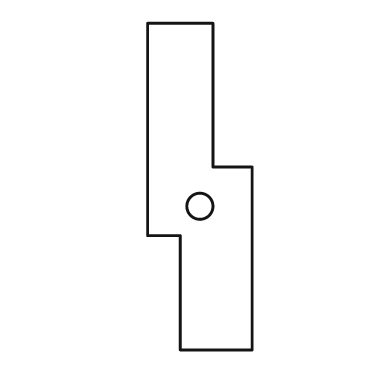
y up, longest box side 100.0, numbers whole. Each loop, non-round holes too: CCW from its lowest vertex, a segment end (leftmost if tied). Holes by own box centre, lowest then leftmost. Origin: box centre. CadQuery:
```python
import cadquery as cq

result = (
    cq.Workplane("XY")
    .moveTo(-6.0, -50.0)
    .lineTo(16.0, -50.0)
    .lineTo(16.0, 6.0)
    .lineTo(4.0, 6.0)
    .lineTo(4.0, 50.0)
    .lineTo(-16.0, 50.0)
    .lineTo(-16.0, -15.0)
    .lineTo(-6.0, -15.0)
    .close()
    .moveTo(0.0, -6.0)
    .circle(4.0)
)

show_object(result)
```